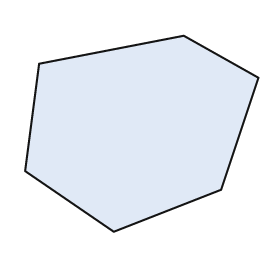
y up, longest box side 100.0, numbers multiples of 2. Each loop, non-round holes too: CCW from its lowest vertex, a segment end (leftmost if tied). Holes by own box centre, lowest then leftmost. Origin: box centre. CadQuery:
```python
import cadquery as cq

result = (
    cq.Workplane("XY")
    .moveTo(-12.0, -42.0)
    .lineTo(34.0, -24.0)
    .lineTo(50.0, 24.0)
    .lineTo(18.0, 42.0)
    .lineTo(-44.0, 30.0)
    .lineTo(-50.0, -16.0)
    .close()
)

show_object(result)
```